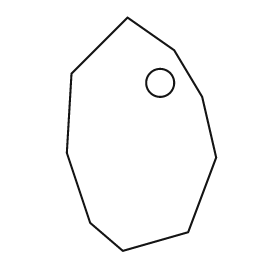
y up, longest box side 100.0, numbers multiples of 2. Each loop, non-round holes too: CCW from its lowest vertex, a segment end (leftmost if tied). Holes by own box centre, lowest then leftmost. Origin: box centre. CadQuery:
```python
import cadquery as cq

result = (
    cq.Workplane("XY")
    .moveTo(-8.0, -50.0)
    .lineTo(20.0, -42.0)
    .lineTo(32.0, -10.0)
    .lineTo(26.0, 16.0)
    .lineTo(14.0, 36.0)
    .lineTo(-6.0, 50.0)
    .lineTo(-30.0, 26.0)
    .lineTo(-32.0, -8.0)
    .lineTo(-22.0, -38.0)
    .close()
    .moveTo(8.0, 22.0)
    .circle(6.0)
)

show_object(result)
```